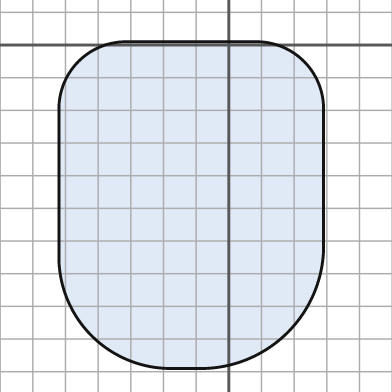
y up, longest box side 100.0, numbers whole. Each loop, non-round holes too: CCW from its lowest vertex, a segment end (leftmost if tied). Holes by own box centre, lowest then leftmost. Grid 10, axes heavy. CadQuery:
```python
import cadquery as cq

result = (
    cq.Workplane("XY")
    .moveTo(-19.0, -99.0)
    .lineTo(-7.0, -99.0)
    .threePointArc((18.0, -88.0), (29.0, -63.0))
    .lineTo(29.0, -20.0)
    .threePointArc((23.0, -5.0), (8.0, 1.0))
    .lineTo(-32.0, 1.0)
    .threePointArc((-46.0, -5.0), (-52.0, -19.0))
    .lineTo(-52.0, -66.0)
    .threePointArc((-42.0, -89.0), (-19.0, -99.0))
    .close()
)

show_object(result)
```